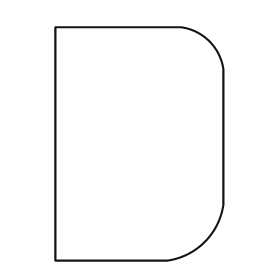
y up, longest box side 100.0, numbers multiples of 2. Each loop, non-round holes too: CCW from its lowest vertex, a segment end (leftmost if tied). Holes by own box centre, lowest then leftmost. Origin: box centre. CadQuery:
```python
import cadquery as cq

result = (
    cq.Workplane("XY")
    .moveTo(-36.0, -50.0)
    .lineTo(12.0, -50.0)
    .threePointArc((28.0, -42.0), (36.0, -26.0))
    .lineTo(36.0, 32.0)
    .threePointArc((30.0, 44.0), (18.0, 50.0))
    .lineTo(-36.0, 50.0)
    .close()
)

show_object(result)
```